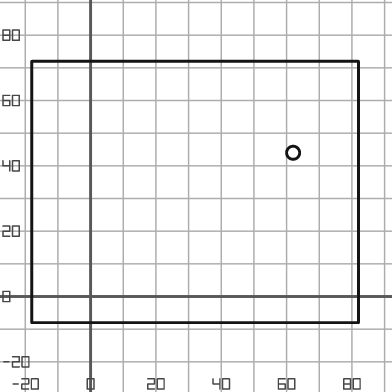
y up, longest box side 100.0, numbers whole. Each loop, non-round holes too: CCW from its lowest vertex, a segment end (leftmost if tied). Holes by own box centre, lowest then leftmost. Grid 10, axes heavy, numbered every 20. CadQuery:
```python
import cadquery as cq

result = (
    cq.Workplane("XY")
    .moveTo(-18.0, -8.0)
    .lineTo(82.0, -8.0)
    .lineTo(82.0, 72.0)
    .lineTo(-18.0, 72.0)
    .close()
    .moveTo(62.0, 44.0)
    .circle(2.0)
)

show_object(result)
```